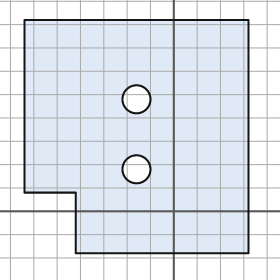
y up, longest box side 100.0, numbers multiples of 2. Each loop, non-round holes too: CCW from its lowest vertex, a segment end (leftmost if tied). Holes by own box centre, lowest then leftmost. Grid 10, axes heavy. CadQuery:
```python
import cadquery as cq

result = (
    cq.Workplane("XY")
    .moveTo(-42.0, -18.0)
    .lineTo(32.0, -18.0)
    .lineTo(32.0, 82.0)
    .lineTo(-64.0, 82.0)
    .lineTo(-64.0, 8.0)
    .lineTo(-42.0, 8.0)
    .close()
    .moveTo(-16.0, 18.0)
    .circle(6.0)
    .moveTo(-16.0, 48.0)
    .circle(6.0)
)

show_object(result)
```